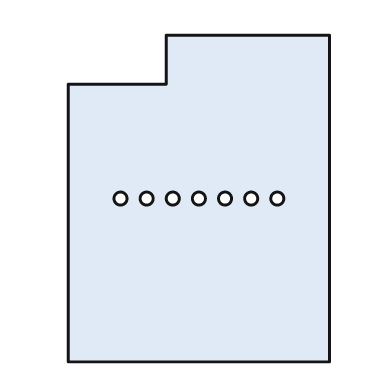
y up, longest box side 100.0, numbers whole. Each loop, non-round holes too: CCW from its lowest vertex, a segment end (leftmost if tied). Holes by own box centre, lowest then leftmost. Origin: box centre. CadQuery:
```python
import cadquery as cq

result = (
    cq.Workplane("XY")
    .moveTo(-40.0, -50.0)
    .lineTo(40.0, -50.0)
    .lineTo(40.0, 50.0)
    .lineTo(-10.0, 50.0)
    .lineTo(-10.0, 35.0)
    .lineTo(-40.0, 35.0)
    .close()
    .moveTo(-24.0, 0.0)
    .circle(2.0)
    .moveTo(-16.0, 0.0)
    .circle(2.0)
    .moveTo(-8.0, 0.0)
    .circle(2.0)
    .moveTo(0.0, 0.0)
    .circle(2.0)
    .moveTo(8.0, 0.0)
    .circle(2.0)
    .moveTo(16.0, 0.0)
    .circle(2.0)
    .moveTo(24.0, 0.0)
    .circle(2.0)
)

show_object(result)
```